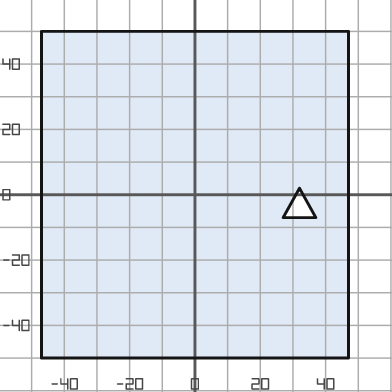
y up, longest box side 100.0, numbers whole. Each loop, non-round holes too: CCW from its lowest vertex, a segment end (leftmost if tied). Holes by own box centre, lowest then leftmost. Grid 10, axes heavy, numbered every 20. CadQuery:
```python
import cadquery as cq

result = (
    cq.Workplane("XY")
    .moveTo(-47.0, -50.0)
    .lineTo(47.0, -50.0)
    .lineTo(47.0, 50.0)
    .lineTo(-47.0, 50.0)
    .close()
    .moveTo(27.0, -7.0)
    .lineTo(37.0, -7.0)
    .lineTo(32.0, 2.0)
    .close()
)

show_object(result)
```